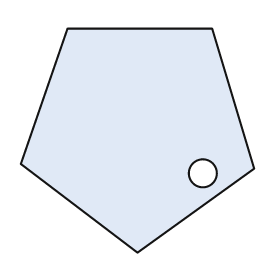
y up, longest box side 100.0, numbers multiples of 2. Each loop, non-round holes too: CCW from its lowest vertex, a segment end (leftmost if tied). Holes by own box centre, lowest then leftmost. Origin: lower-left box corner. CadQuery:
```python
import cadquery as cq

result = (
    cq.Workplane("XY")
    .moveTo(50.0, 0.0)
    .lineTo(100.0, 36.0)
    .lineTo(82.0, 96.0)
    .lineTo(20.0, 96.0)
    .lineTo(0.0, 38.0)
    .close()
    .moveTo(78.0, 34.0)
    .circle(6.0)
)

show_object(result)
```